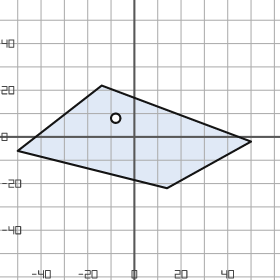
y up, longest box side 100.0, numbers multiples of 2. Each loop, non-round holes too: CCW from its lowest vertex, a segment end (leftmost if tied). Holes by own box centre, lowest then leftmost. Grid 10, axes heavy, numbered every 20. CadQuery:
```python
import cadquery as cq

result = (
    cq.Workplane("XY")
    .moveTo(14.0, -22.0)
    .lineTo(50.0, -2.0)
    .lineTo(-14.0, 22.0)
    .lineTo(-50.0, -6.0)
    .close()
    .moveTo(-8.0, 8.0)
    .circle(2.0)
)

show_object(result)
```